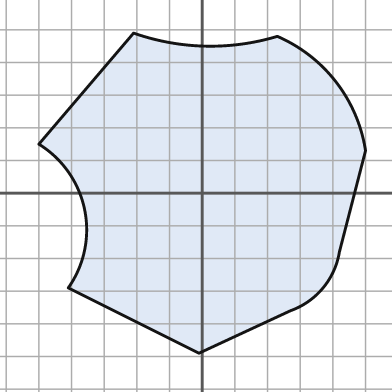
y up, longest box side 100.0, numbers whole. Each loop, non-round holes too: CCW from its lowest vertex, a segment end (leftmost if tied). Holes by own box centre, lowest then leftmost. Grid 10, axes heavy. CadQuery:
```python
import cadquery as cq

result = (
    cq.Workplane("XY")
    .moveTo(-1.0, -49.0)
    .lineTo(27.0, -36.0)
    .threePointArc((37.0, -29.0), (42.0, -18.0))
    .lineTo(50.0, 13.0)
    .threePointArc((41.0, 34.0), (23.0, 48.0))
    .threePointArc((1.0, 45.0), (-21.0, 49.0))
    .lineTo(-50.0, 15.0)
    .threePointArc((-36.0, -5.0), (-41.0, -29.0))
    .close()
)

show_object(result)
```